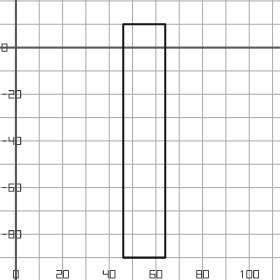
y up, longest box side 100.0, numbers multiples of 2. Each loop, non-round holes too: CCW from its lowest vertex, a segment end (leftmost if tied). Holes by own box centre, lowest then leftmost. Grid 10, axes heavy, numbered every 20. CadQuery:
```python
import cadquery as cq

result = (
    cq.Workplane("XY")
    .moveTo(46.0, -90.0)
    .lineTo(64.0, -90.0)
    .lineTo(64.0, 10.0)
    .lineTo(46.0, 10.0)
    .close()
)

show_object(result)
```